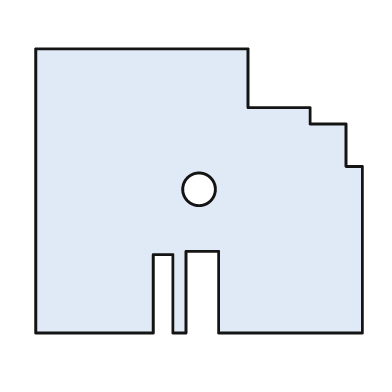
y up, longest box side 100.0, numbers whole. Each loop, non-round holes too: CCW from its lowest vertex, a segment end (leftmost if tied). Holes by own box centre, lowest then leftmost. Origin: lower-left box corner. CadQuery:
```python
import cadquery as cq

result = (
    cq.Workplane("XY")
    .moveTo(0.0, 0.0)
    .lineTo(36.0, 0.0)
    .lineTo(36.0, 24.0)
    .lineTo(42.0, 24.0)
    .lineTo(42.0, 0.0)
    .lineTo(46.0, 0.0)
    .lineTo(46.0, 25.0)
    .lineTo(56.0, 25.0)
    .lineTo(56.0, 0.0)
    .lineTo(100.0, 0.0)
    .lineTo(100.0, 51.0)
    .lineTo(95.0, 51.0)
    .lineTo(95.0, 64.0)
    .lineTo(84.0, 64.0)
    .lineTo(84.0, 69.0)
    .lineTo(65.0, 69.0)
    .lineTo(65.0, 87.0)
    .lineTo(0.0, 87.0)
    .close()
    .moveTo(50.0, 44.0)
    .circle(5.0)
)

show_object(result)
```